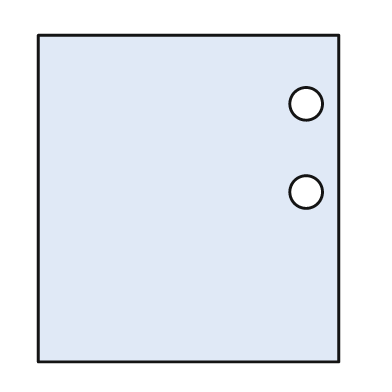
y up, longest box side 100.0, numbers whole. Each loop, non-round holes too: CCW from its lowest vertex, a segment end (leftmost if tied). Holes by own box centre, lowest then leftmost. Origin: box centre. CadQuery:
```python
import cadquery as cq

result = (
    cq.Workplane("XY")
    .moveTo(-46.0, -50.0)
    .lineTo(46.0, -50.0)
    .lineTo(46.0, 50.0)
    .lineTo(-46.0, 50.0)
    .close()
    .moveTo(36.0, 2.0)
    .circle(5.0)
    .moveTo(36.0, 29.0)
    .circle(5.0)
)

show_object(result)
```